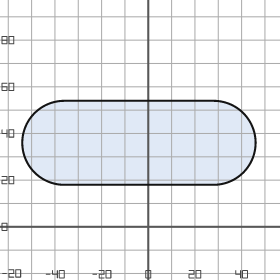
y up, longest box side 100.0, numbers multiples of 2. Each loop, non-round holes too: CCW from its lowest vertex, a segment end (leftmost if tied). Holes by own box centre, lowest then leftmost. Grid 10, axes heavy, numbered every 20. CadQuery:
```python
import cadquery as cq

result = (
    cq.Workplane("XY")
    .moveTo(-36.0, 18.0)
    .lineTo(28.0, 18.0)
    .threePointArc((46.0, 36.0), (28.0, 54.0))
    .lineTo(-36.0, 54.0)
    .threePointArc((-54.0, 36.0), (-36.0, 18.0))
    .close()
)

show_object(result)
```